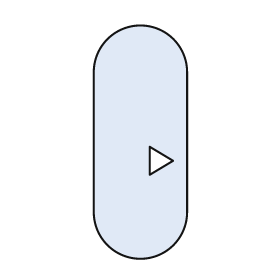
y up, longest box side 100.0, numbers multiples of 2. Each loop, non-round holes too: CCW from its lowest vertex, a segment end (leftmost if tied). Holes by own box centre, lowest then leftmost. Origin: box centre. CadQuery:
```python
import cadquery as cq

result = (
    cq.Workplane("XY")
    .moveTo(-20.0, -30.0)
    .threePointArc((0.0, -50.0), (20.0, -30.0))
    .lineTo(20.0, 30.0)
    .threePointArc((0.0, 50.0), (-20.0, 30.0))
    .close()
    .moveTo(4.0, -14.0)
    .lineTo(14.0, -8.0)
    .lineTo(4.0, -2.0)
    .close()
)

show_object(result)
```